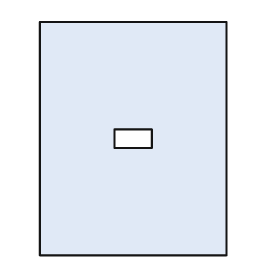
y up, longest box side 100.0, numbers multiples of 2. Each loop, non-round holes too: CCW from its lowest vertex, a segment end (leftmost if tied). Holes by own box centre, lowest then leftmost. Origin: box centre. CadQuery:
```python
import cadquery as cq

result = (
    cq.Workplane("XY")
    .moveTo(-40.0, -50.0)
    .lineTo(40.0, -50.0)
    .lineTo(40.0, 50.0)
    .lineTo(-40.0, 50.0)
    .close()
    .moveTo(-8.0, -4.0)
    .lineTo(8.0, -4.0)
    .lineTo(8.0, 4.0)
    .lineTo(-8.0, 4.0)
    .close()
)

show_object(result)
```